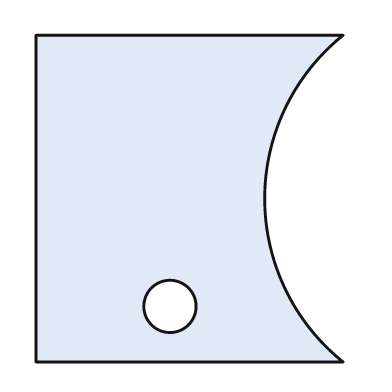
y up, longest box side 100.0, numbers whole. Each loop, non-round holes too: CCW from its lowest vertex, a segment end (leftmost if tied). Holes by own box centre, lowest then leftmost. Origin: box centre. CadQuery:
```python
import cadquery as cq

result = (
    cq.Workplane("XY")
    .moveTo(-47.0, -50.0)
    .lineTo(47.0, -50.0)
    .threePointArc((23.0, 0.0), (47.0, 50.0))
    .lineTo(-47.0, 50.0)
    .close()
    .moveTo(-6.0, -33.0)
    .circle(8.0)
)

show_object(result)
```